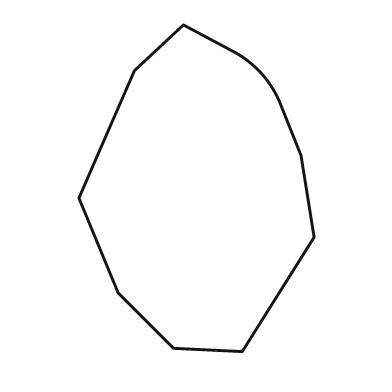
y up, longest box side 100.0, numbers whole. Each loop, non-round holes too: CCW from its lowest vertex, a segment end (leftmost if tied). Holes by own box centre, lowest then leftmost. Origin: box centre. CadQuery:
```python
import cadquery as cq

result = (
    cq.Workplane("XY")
    .moveTo(14.0, -50.0)
    .lineTo(36.0, -15.0)
    .lineTo(32.0, 10.0)
    .lineTo(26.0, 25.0)
    .threePointArc((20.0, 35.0), (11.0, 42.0))
    .lineTo(-4.0, 50.0)
    .lineTo(-19.0, 36.0)
    .lineTo(-36.0, -3.0)
    .lineTo(-24.0, -32.0)
    .lineTo(-7.0, -49.0)
    .close()
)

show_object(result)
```